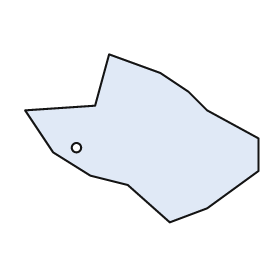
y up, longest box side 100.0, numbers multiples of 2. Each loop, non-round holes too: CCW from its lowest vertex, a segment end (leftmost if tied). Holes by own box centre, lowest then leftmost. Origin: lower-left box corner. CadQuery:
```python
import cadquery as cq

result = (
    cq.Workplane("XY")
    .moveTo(62.0, 0.0)
    .lineTo(78.0, 6.0)
    .lineTo(100.0, 22.0)
    .lineTo(100.0, 36.0)
    .lineTo(78.0, 48.0)
    .lineTo(70.0, 56.0)
    .lineTo(58.0, 64.0)
    .lineTo(36.0, 72.0)
    .lineTo(30.0, 50.0)
    .lineTo(0.0, 48.0)
    .lineTo(12.0, 30.0)
    .lineTo(28.0, 20.0)
    .lineTo(44.0, 16.0)
    .close()
    .moveTo(22.0, 32.0)
    .circle(2.0)
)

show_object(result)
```